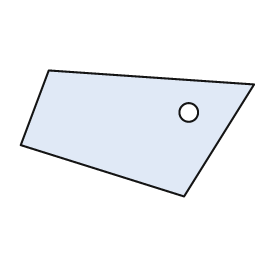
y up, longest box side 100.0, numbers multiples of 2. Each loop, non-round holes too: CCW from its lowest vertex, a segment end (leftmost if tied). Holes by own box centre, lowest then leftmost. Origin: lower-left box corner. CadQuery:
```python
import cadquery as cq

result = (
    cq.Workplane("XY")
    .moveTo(70.0, 0.0)
    .lineTo(100.0, 48.0)
    .lineTo(12.0, 54.0)
    .lineTo(0.0, 22.0)
    .close()
    .moveTo(72.0, 36.0)
    .circle(4.0)
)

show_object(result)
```